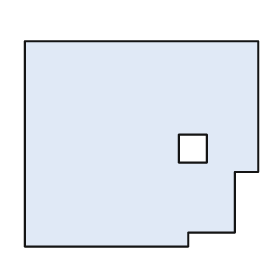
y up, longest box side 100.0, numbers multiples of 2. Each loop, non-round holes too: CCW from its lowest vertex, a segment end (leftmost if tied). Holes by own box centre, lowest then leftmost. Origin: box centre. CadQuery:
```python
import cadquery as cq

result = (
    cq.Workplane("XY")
    .moveTo(-50.0, -44.0)
    .lineTo(20.0, -44.0)
    .lineTo(20.0, -38.0)
    .lineTo(40.0, -38.0)
    .lineTo(40.0, -12.0)
    .lineTo(50.0, -12.0)
    .lineTo(50.0, 44.0)
    .lineTo(-50.0, 44.0)
    .close()
    .moveTo(16.0, -8.0)
    .lineTo(28.0, -8.0)
    .lineTo(28.0, 4.0)
    .lineTo(16.0, 4.0)
    .close()
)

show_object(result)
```